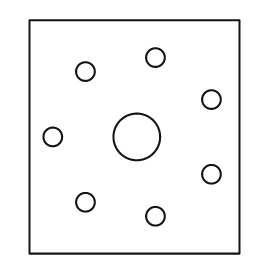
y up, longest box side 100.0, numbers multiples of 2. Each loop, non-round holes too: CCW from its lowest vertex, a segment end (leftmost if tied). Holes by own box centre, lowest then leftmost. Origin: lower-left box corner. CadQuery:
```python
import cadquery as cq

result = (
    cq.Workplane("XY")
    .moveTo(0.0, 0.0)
    .lineTo(90.0, 0.0)
    .lineTo(90.0, 100.0)
    .lineTo(0.0, 100.0)
    .close()
    .moveTo(54.0, 16.0)
    .circle(4.0)
    .moveTo(24.0, 22.0)
    .circle(4.0)
    .moveTo(78.0, 34.0)
    .circle(4.0)
    .moveTo(10.0, 50.0)
    .circle(4.0)
    .moveTo(46.0, 50.0)
    .circle(10.0)
    .moveTo(78.0, 66.0)
    .circle(4.0)
    .moveTo(24.0, 78.0)
    .circle(4.0)
    .moveTo(54.0, 84.0)
    .circle(4.0)
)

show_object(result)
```